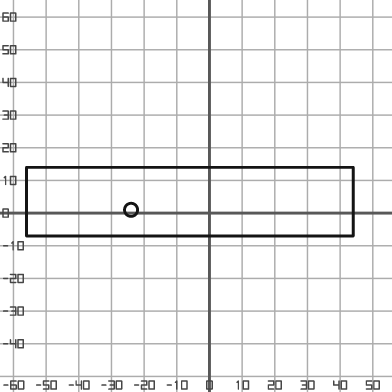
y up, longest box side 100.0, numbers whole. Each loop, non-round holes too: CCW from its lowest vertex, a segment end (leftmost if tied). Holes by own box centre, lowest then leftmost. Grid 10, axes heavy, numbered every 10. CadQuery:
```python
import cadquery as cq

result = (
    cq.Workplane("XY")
    .moveTo(-56.0, -7.0)
    .lineTo(44.0, -7.0)
    .lineTo(44.0, 14.0)
    .lineTo(-56.0, 14.0)
    .close()
    .moveTo(-24.0, 1.0)
    .circle(2.0)
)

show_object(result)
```